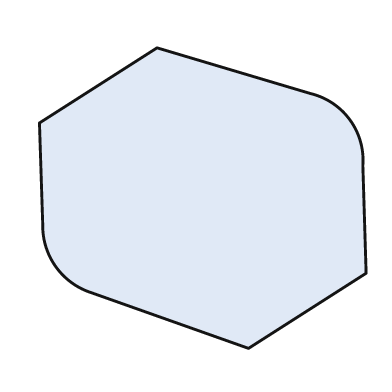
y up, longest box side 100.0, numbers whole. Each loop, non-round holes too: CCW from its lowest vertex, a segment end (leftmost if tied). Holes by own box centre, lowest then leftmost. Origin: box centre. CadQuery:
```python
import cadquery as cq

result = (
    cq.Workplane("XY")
    .moveTo(14.0, -46.0)
    .lineTo(50.0, -23.0)
    .lineTo(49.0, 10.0)
    .threePointArc((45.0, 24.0), (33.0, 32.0))
    .lineTo(-14.0, 46.0)
    .lineTo(-50.0, 23.0)
    .lineTo(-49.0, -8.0)
    .threePointArc((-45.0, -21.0), (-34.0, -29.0))
    .close()
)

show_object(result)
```